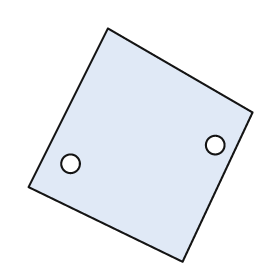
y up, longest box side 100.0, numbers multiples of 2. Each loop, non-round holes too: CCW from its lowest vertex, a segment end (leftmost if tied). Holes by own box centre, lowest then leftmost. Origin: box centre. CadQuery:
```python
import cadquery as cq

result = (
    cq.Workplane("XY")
    .moveTo(18.0, -50.0)
    .lineTo(48.0, 14.0)
    .lineTo(-14.0, 50.0)
    .lineTo(-48.0, -18.0)
    .close()
    .moveTo(-30.0, -8.0)
    .circle(4.0)
    .moveTo(32.0, 0.0)
    .circle(4.0)
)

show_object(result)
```